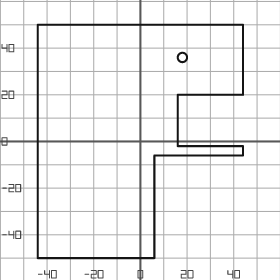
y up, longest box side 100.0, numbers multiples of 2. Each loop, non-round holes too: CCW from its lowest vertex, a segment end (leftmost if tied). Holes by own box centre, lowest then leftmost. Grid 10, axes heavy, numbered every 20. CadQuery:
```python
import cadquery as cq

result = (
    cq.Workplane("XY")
    .moveTo(-44.0, -50.0)
    .lineTo(6.0, -50.0)
    .lineTo(6.0, -6.0)
    .lineTo(44.0, -6.0)
    .lineTo(44.0, -2.0)
    .lineTo(16.0, -2.0)
    .lineTo(16.0, 20.0)
    .lineTo(44.0, 20.0)
    .lineTo(44.0, 50.0)
    .lineTo(-44.0, 50.0)
    .close()
    .moveTo(18.0, 36.0)
    .circle(2.0)
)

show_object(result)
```